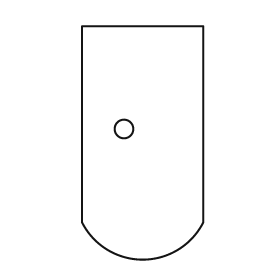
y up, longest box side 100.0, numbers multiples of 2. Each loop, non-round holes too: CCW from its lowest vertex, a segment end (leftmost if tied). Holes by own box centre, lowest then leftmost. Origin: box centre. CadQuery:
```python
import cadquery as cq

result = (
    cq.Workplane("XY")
    .moveTo(-26.0, -34.0)
    .threePointArc((0.0, -50.0), (26.0, -34.0))
    .lineTo(26.0, 50.0)
    .lineTo(-26.0, 50.0)
    .close()
    .moveTo(-8.0, 6.0)
    .circle(4.0)
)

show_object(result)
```